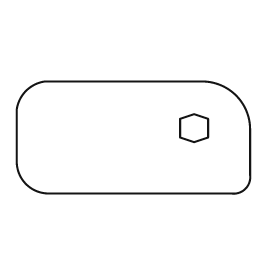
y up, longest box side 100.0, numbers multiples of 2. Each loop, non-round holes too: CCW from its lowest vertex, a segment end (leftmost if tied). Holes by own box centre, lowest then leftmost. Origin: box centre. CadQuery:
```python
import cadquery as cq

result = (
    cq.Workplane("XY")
    .moveTo(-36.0, -24.0)
    .lineTo(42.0, -24.0)
    .threePointArc((48.0, -22.0), (50.0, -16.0))
    .lineTo(50.0, 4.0)
    .threePointArc((44.0, 18.0), (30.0, 24.0))
    .lineTo(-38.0, 24.0)
    .threePointArc((-46.0, 20.0), (-50.0, 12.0))
    .lineTo(-50.0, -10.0)
    .threePointArc((-46.0, -20.0), (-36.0, -24.0))
    .close()
    .moveTo(26.0, -2.0)
    .lineTo(32.0, 0.0)
    .lineTo(32.0, 8.0)
    .lineTo(26.0, 10.0)
    .lineTo(20.0, 8.0)
    .lineTo(20.0, 0.0)
    .close()
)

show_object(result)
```